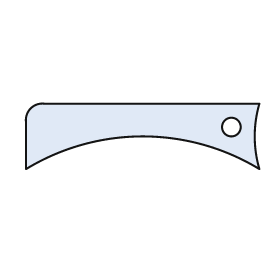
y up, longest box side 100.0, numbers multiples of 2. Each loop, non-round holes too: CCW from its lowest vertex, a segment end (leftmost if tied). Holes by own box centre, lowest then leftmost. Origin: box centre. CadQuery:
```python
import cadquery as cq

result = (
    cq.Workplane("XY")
    .moveTo(-50.0, -14.0)
    .threePointArc((0.0, 0.0), (50.0, -14.0))
    .threePointArc((48.0, 0.0), (50.0, 14.0))
    .lineTo(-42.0, 14.0)
    .threePointArc((-48.0, 12.0), (-50.0, 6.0))
    .close()
    .moveTo(38.0, 4.0)
    .circle(4.0)
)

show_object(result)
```